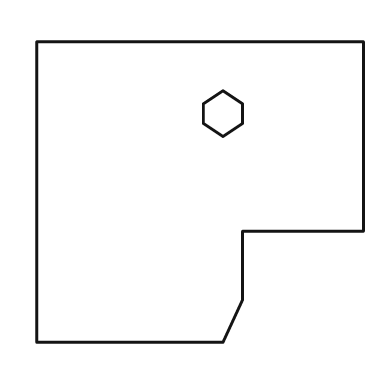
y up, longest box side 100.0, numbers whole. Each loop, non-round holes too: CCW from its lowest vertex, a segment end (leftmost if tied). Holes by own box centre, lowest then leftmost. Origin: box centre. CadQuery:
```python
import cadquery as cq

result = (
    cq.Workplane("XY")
    .moveTo(-50.0, -46.0)
    .lineTo(7.0, -46.0)
    .lineTo(13.0, -33.0)
    .lineTo(13.0, -12.0)
    .lineTo(50.0, -12.0)
    .lineTo(50.0, 46.0)
    .lineTo(-50.0, 46.0)
    .close()
    .moveTo(7.0, 17.0)
    .lineTo(13.0, 21.0)
    .lineTo(13.0, 27.0)
    .lineTo(7.0, 31.0)
    .lineTo(1.0, 27.0)
    .lineTo(1.0, 21.0)
    .close()
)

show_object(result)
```